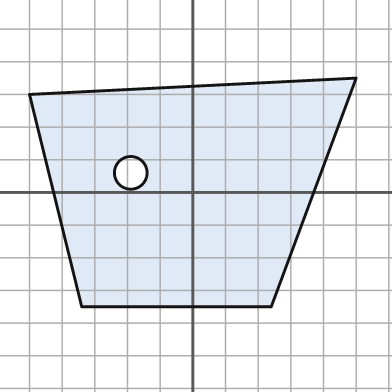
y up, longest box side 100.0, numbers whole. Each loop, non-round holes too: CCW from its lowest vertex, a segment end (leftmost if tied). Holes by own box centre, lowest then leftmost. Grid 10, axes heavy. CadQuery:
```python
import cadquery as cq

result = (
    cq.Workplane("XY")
    .moveTo(-34.0, -35.0)
    .lineTo(24.0, -35.0)
    .lineTo(50.0, 35.0)
    .lineTo(-50.0, 30.0)
    .close()
    .moveTo(-19.0, 6.0)
    .circle(5.0)
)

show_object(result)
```